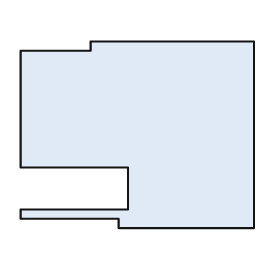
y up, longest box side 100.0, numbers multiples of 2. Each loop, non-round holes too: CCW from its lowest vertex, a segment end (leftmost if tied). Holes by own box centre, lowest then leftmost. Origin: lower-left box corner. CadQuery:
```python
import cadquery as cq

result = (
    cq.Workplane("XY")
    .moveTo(42.0, 0.0)
    .lineTo(100.0, 0.0)
    .lineTo(100.0, 80.0)
    .lineTo(30.0, 80.0)
    .lineTo(30.0, 76.0)
    .lineTo(0.0, 76.0)
    .lineTo(0.0, 26.0)
    .lineTo(46.0, 26.0)
    .lineTo(46.0, 8.0)
    .lineTo(0.0, 8.0)
    .lineTo(0.0, 4.0)
    .lineTo(42.0, 4.0)
    .close()
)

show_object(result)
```